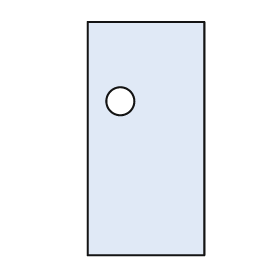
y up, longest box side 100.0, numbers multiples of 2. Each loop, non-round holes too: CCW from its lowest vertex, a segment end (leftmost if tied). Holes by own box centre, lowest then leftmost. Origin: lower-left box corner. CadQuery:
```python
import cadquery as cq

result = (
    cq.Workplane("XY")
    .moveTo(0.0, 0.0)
    .lineTo(50.0, 0.0)
    .lineTo(50.0, 100.0)
    .lineTo(0.0, 100.0)
    .close()
    .moveTo(14.0, 66.0)
    .circle(6.0)
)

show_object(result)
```